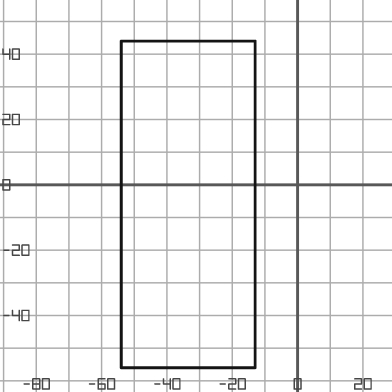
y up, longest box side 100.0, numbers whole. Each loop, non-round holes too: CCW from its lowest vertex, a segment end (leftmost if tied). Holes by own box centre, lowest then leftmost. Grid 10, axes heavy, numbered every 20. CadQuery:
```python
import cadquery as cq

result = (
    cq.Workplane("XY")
    .moveTo(-54.0, -56.0)
    .lineTo(-13.0, -56.0)
    .lineTo(-13.0, 44.0)
    .lineTo(-54.0, 44.0)
    .close()
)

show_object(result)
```